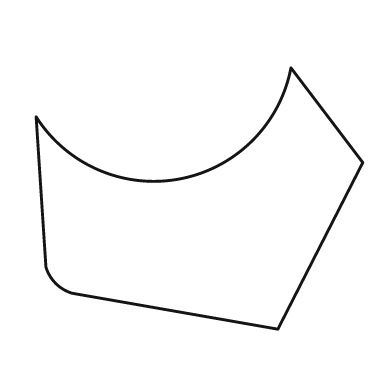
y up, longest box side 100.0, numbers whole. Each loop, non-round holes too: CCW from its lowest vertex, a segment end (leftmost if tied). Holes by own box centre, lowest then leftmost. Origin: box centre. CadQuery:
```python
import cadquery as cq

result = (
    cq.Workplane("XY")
    .moveTo(24.0, -40.0)
    .lineTo(50.0, 11.0)
    .lineTo(28.0, 40.0)
    .threePointArc((-6.0, 6.0), (-50.0, 25.0))
    .lineTo(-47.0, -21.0)
    .threePointArc((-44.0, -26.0), (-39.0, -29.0))
    .close()
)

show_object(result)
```